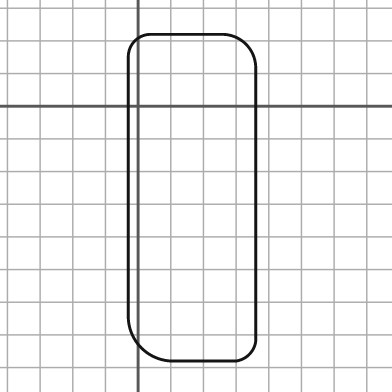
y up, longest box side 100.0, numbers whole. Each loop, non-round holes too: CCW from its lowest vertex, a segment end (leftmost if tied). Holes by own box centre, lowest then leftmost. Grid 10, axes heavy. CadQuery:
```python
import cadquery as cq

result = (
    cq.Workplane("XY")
    .moveTo(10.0, -78.0)
    .lineTo(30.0, -78.0)
    .threePointArc((34.0, -76.0), (36.0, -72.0))
    .lineTo(36.0, 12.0)
    .threePointArc((33.0, 19.0), (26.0, 22.0))
    .lineTo(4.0, 22.0)
    .threePointArc((-1.0, 20.0), (-3.0, 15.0))
    .lineTo(-3.0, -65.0)
    .threePointArc((1.0, -74.0), (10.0, -78.0))
    .close()
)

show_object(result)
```